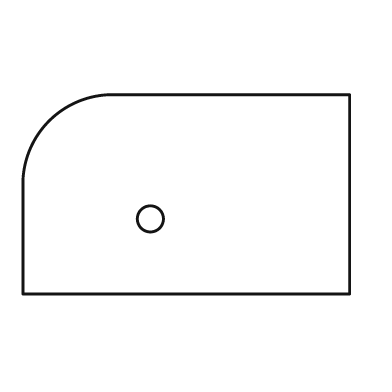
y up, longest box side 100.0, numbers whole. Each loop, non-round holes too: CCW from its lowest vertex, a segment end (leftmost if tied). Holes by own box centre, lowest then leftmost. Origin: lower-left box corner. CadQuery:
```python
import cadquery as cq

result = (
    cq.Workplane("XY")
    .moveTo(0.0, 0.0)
    .lineTo(100.0, 0.0)
    .lineTo(100.0, 61.0)
    .lineTo(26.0, 61.0)
    .threePointArc((8.0, 53.0), (0.0, 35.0))
    .close()
    .moveTo(39.0, 23.0)
    .circle(4.0)
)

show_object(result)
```